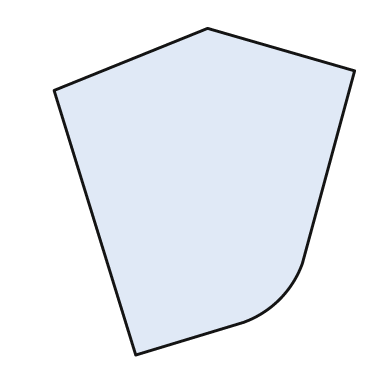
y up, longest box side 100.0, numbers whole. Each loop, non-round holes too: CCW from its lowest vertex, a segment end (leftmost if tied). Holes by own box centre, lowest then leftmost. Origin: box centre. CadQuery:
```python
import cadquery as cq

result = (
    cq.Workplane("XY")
    .moveTo(-21.0, -50.0)
    .lineTo(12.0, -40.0)
    .threePointArc((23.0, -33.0), (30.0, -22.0))
    .lineTo(46.0, 37.0)
    .lineTo(1.0, 50.0)
    .lineTo(-46.0, 31.0)
    .close()
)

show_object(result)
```